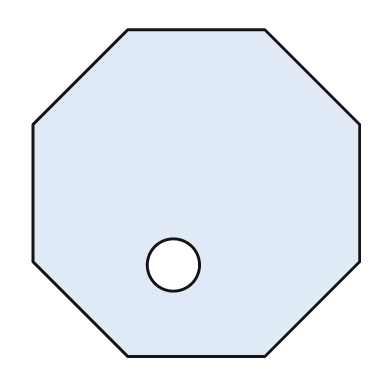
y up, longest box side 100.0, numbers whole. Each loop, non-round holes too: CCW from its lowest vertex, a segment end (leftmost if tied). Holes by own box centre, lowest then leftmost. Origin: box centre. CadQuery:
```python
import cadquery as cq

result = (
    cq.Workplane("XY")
    .moveTo(-21.0, -50.0)
    .lineTo(21.0, -50.0)
    .lineTo(50.0, -21.0)
    .lineTo(50.0, 21.0)
    .lineTo(21.0, 50.0)
    .lineTo(-21.0, 50.0)
    .lineTo(-50.0, 21.0)
    .lineTo(-50.0, -21.0)
    .close()
    .moveTo(-7.0, -22.0)
    .circle(8.0)
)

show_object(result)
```